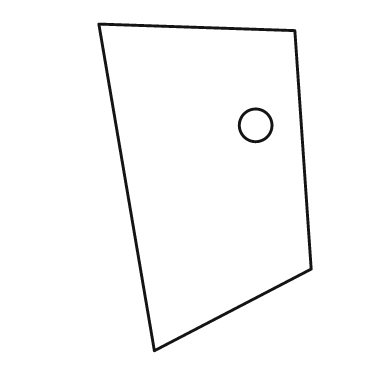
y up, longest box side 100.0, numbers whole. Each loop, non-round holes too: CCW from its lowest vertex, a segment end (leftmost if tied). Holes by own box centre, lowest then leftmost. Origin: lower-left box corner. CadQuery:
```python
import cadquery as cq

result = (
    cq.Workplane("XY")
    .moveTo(17.0, 0.0)
    .lineTo(65.0, 25.0)
    .lineTo(60.0, 98.0)
    .lineTo(0.0, 100.0)
    .close()
    .moveTo(48.0, 69.0)
    .circle(5.0)
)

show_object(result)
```